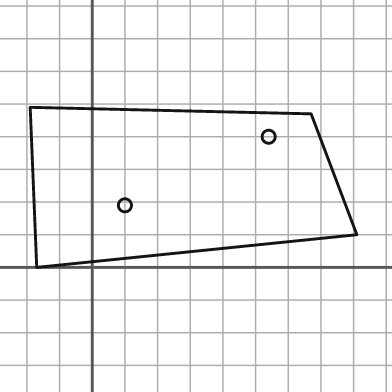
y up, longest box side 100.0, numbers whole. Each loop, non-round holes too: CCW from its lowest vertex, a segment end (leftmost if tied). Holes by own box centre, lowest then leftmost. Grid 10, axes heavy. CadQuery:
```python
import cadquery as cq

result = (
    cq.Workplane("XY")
    .moveTo(-17.0, 0.0)
    .lineTo(81.0, 10.0)
    .lineTo(67.0, 47.0)
    .lineTo(-19.0, 49.0)
    .close()
    .moveTo(10.0, 19.0)
    .circle(2.0)
    .moveTo(54.0, 40.0)
    .circle(2.0)
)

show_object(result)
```